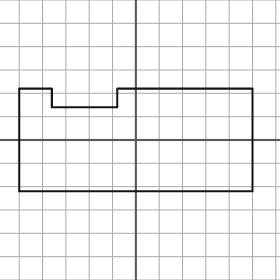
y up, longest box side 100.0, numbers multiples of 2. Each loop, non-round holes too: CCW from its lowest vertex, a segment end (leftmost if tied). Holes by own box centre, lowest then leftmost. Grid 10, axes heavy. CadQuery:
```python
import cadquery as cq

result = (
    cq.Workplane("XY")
    .moveTo(-50.0, -22.0)
    .lineTo(50.0, -22.0)
    .lineTo(50.0, 22.0)
    .lineTo(-8.0, 22.0)
    .lineTo(-8.0, 14.0)
    .lineTo(-36.0, 14.0)
    .lineTo(-36.0, 22.0)
    .lineTo(-50.0, 22.0)
    .close()
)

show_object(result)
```